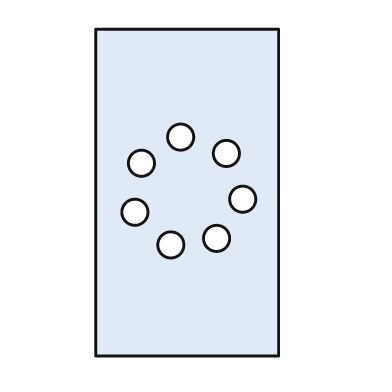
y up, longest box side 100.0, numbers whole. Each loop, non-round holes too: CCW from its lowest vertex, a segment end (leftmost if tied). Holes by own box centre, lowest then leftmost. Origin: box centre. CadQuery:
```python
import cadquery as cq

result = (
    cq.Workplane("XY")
    .moveTo(-28.0, -50.0)
    .lineTo(28.0, -50.0)
    .lineTo(28.0, 50.0)
    .lineTo(-28.0, 50.0)
    .close()
    .moveTo(-5.0, -16.0)
    .circle(4.0)
    .moveTo(9.0, -14.0)
    .circle(4.0)
    .moveTo(-16.0, -6.0)
    .circle(4.0)
    .moveTo(17.0, -2.0)
    .circle(4.0)
    .moveTo(-14.0, 9.0)
    .circle(4.0)
    .moveTo(12.0, 12.0)
    .circle(4.0)
    .moveTo(-2.0, 17.0)
    .circle(4.0)
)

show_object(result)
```